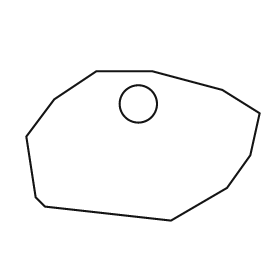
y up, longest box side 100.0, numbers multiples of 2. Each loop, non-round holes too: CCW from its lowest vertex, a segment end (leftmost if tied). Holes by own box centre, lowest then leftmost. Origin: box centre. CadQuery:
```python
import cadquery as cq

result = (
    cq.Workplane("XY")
    .moveTo(12.0, -32.0)
    .lineTo(36.0, -18.0)
    .lineTo(46.0, -4.0)
    .lineTo(50.0, 14.0)
    .lineTo(34.0, 24.0)
    .lineTo(4.0, 32.0)
    .lineTo(-20.0, 32.0)
    .lineTo(-38.0, 20.0)
    .lineTo(-50.0, 4.0)
    .lineTo(-46.0, -22.0)
    .lineTo(-42.0, -26.0)
    .close()
    .moveTo(-2.0, 18.0)
    .circle(8.0)
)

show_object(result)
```